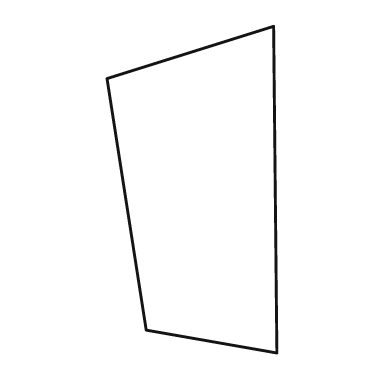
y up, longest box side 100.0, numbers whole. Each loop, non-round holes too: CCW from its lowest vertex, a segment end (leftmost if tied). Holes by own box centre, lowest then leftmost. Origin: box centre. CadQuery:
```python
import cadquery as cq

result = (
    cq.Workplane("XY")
    .moveTo(26.0, -50.0)
    .lineTo(25.0, 50.0)
    .lineTo(-26.0, 34.0)
    .lineTo(-14.0, -43.0)
    .close()
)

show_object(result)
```